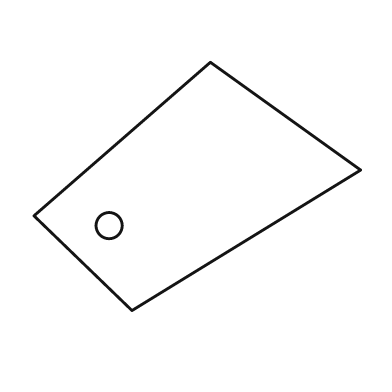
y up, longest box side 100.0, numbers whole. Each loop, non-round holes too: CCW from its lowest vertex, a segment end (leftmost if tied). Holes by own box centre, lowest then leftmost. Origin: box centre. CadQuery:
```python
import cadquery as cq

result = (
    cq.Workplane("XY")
    .moveTo(-20.0, -38.0)
    .lineTo(50.0, 5.0)
    .lineTo(4.0, 38.0)
    .lineTo(-50.0, -9.0)
    .close()
    .moveTo(-27.0, -12.0)
    .circle(4.0)
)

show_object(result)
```